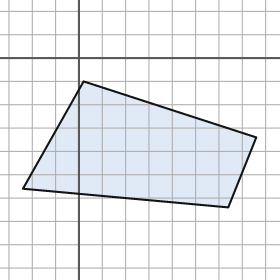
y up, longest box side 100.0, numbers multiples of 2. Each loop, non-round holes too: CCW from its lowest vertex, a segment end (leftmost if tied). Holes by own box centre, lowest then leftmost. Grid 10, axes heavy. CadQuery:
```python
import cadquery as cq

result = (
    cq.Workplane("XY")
    .moveTo(64.0, -64.0)
    .lineTo(76.0, -34.0)
    .lineTo(2.0, -10.0)
    .lineTo(-24.0, -56.0)
    .close()
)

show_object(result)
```